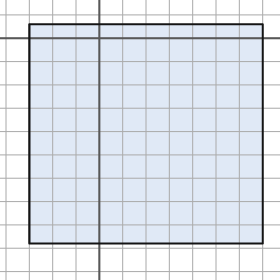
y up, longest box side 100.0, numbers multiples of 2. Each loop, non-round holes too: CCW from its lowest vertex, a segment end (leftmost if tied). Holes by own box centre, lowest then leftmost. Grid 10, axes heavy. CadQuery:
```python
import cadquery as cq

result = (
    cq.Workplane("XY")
    .moveTo(-30.0, -88.0)
    .lineTo(70.0, -88.0)
    .lineTo(70.0, 6.0)
    .lineTo(-30.0, 6.0)
    .close()
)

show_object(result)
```